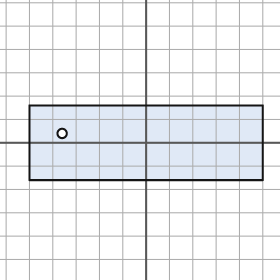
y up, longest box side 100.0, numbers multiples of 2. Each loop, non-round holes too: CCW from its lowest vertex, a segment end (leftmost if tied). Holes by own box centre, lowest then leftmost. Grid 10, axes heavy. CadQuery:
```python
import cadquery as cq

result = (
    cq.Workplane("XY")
    .moveTo(-50.0, -16.0)
    .lineTo(50.0, -16.0)
    .lineTo(50.0, 16.0)
    .lineTo(-50.0, 16.0)
    .close()
    .moveTo(-36.0, 4.0)
    .circle(2.0)
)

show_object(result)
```